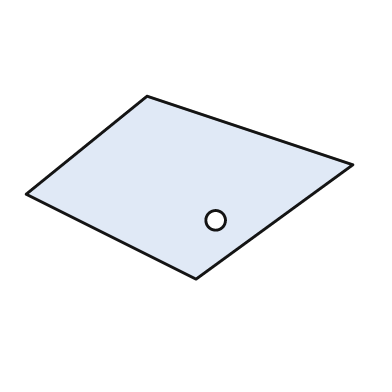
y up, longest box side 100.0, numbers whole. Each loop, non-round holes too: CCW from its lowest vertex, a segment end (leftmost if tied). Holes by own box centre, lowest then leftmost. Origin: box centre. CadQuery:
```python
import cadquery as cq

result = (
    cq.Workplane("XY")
    .moveTo(2.0, -28.0)
    .lineTo(50.0, 7.0)
    .lineTo(-13.0, 28.0)
    .lineTo(-50.0, -2.0)
    .close()
    .moveTo(8.0, -10.0)
    .circle(3.0)
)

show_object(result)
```